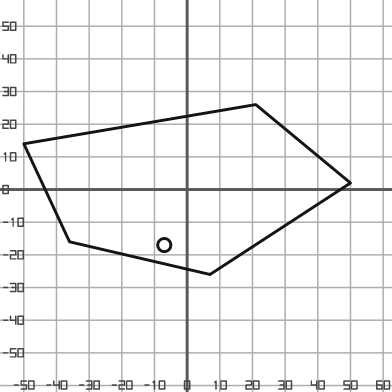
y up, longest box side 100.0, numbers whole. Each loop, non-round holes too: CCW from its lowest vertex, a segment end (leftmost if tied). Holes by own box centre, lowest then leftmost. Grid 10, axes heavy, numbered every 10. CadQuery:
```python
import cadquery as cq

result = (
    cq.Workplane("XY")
    .moveTo(7.0, -26.0)
    .lineTo(50.0, 2.0)
    .lineTo(21.0, 26.0)
    .lineTo(-50.0, 14.0)
    .lineTo(-36.0, -16.0)
    .close()
    .moveTo(-7.0, -17.0)
    .circle(2.0)
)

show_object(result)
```